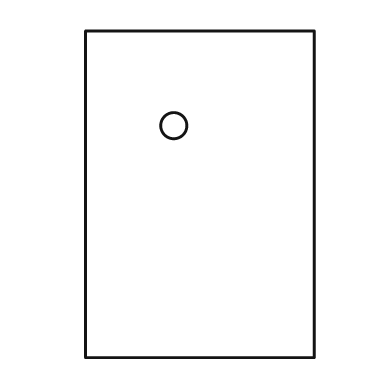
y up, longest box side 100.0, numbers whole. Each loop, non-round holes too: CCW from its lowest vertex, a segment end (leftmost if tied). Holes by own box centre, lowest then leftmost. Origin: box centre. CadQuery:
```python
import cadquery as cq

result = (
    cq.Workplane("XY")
    .moveTo(-35.0, -50.0)
    .lineTo(35.0, -50.0)
    .lineTo(35.0, 50.0)
    .lineTo(-35.0, 50.0)
    .close()
    .moveTo(-8.0, 21.0)
    .circle(4.0)
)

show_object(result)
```